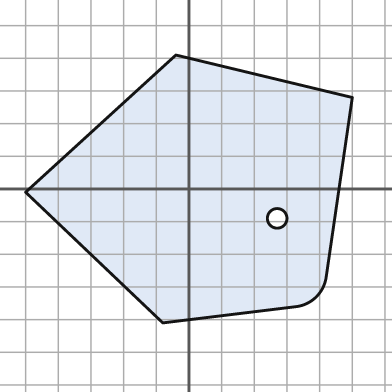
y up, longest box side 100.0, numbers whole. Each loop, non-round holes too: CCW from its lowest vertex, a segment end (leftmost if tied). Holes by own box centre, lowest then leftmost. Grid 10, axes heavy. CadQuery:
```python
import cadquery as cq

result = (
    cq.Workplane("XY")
    .moveTo(-8.0, -41.0)
    .lineTo(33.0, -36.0)
    .threePointArc((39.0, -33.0), (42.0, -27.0))
    .lineTo(50.0, 28.0)
    .lineTo(-4.0, 41.0)
    .lineTo(-50.0, -1.0)
    .close()
    .moveTo(27.0, -9.0)
    .circle(3.0)
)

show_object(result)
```